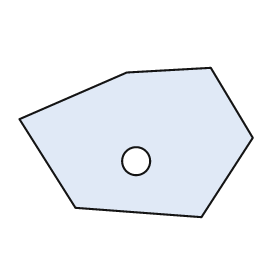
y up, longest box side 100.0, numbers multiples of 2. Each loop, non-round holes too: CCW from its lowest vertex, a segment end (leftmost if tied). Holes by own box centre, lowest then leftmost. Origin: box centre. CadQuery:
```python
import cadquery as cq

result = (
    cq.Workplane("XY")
    .moveTo(28.0, -32.0)
    .lineTo(50.0, 2.0)
    .lineTo(32.0, 32.0)
    .lineTo(-4.0, 30.0)
    .lineTo(-50.0, 10.0)
    .lineTo(-26.0, -28.0)
    .close()
    .moveTo(0.0, -8.0)
    .circle(6.0)
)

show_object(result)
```